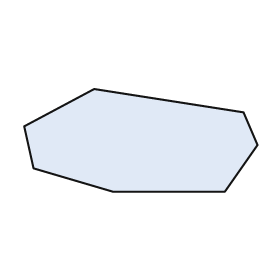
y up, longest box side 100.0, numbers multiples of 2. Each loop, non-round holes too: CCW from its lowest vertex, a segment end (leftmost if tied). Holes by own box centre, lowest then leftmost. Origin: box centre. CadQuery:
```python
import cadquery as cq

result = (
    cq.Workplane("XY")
    .moveTo(-12.0, -22.0)
    .lineTo(36.0, -22.0)
    .lineTo(50.0, -2.0)
    .lineTo(44.0, 12.0)
    .lineTo(-20.0, 22.0)
    .lineTo(-50.0, 6.0)
    .lineTo(-46.0, -12.0)
    .close()
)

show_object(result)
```